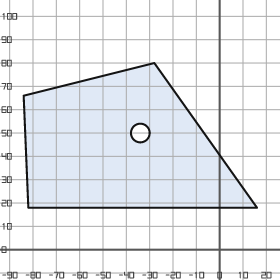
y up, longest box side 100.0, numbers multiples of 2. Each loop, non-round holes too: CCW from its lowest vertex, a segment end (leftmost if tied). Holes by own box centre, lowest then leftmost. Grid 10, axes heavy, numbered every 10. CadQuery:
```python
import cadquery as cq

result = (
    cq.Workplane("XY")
    .moveTo(-82.0, 18.0)
    .lineTo(16.0, 18.0)
    .lineTo(-28.0, 80.0)
    .lineTo(-84.0, 66.0)
    .close()
    .moveTo(-34.0, 50.0)
    .circle(4.0)
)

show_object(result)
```